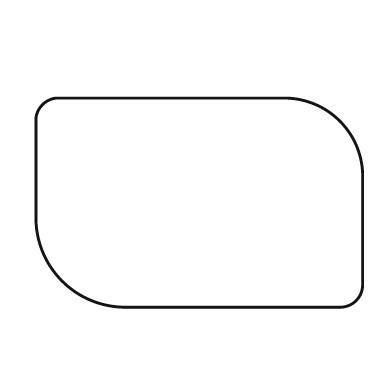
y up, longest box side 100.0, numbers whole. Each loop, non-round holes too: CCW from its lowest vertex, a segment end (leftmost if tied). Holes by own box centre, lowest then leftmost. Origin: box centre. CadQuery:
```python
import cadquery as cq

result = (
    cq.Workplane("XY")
    .moveTo(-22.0, -32.0)
    .lineTo(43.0, -32.0)
    .threePointArc((48.0, -30.0), (50.0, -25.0))
    .lineTo(50.0, 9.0)
    .threePointArc((43.0, 25.0), (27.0, 32.0))
    .lineTo(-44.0, 32.0)
    .threePointArc((-48.0, 30.0), (-50.0, 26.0))
    .lineTo(-50.0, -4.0)
    .threePointArc((-42.0, -24.0), (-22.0, -32.0))
    .close()
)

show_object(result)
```